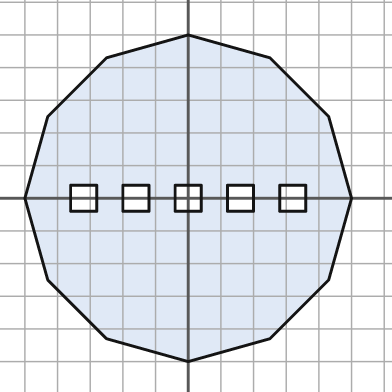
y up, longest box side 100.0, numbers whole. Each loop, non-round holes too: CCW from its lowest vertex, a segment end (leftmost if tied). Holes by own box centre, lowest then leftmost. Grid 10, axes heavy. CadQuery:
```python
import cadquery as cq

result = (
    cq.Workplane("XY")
    .moveTo(0.0, -50.0)
    .lineTo(25.0, -43.0)
    .lineTo(43.0, -25.0)
    .lineTo(50.0, 0.0)
    .lineTo(43.0, 25.0)
    .lineTo(25.0, 43.0)
    .lineTo(0.0, 50.0)
    .lineTo(-25.0, 43.0)
    .lineTo(-43.0, 25.0)
    .lineTo(-50.0, 0.0)
    .lineTo(-43.0, -25.0)
    .lineTo(-25.0, -43.0)
    .close()
    .moveTo(-36.0, -4.0)
    .lineTo(-28.0, -4.0)
    .lineTo(-28.0, 4.0)
    .lineTo(-36.0, 4.0)
    .close()
    .moveTo(-20.0, -4.0)
    .lineTo(-12.0, -4.0)
    .lineTo(-12.0, 4.0)
    .lineTo(-20.0, 4.0)
    .close()
    .moveTo(-4.0, -4.0)
    .lineTo(4.0, -4.0)
    .lineTo(4.0, 4.0)
    .lineTo(-4.0, 4.0)
    .close()
    .moveTo(12.0, -4.0)
    .lineTo(20.0, -4.0)
    .lineTo(20.0, 4.0)
    .lineTo(12.0, 4.0)
    .close()
    .moveTo(28.0, -4.0)
    .lineTo(36.0, -4.0)
    .lineTo(36.0, 4.0)
    .lineTo(28.0, 4.0)
    .close()
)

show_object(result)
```